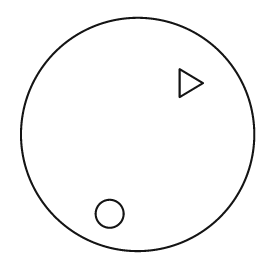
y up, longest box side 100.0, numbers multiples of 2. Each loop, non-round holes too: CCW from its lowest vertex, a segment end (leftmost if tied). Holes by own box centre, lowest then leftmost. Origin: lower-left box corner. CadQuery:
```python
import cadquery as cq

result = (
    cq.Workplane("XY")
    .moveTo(50.0, 50.0)
    .circle(50.0)
    .moveTo(38.0, 16.0)
    .circle(6.0)
    .moveTo(68.0, 66.0)
    .lineTo(78.0, 72.0)
    .lineTo(68.0, 78.0)
    .close()
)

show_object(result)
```